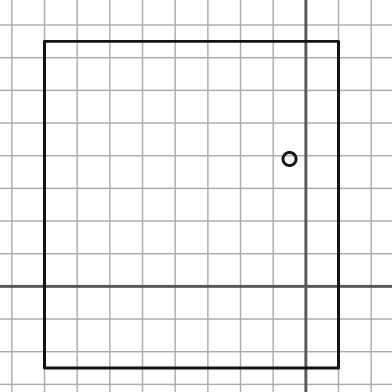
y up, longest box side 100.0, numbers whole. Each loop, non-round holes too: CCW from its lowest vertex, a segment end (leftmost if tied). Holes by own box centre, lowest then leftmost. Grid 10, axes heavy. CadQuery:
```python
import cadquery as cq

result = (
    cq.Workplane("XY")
    .moveTo(-80.0, -25.0)
    .lineTo(10.0, -25.0)
    .lineTo(10.0, 75.0)
    .lineTo(-80.0, 75.0)
    .close()
    .moveTo(-5.0, 39.0)
    .circle(2.0)
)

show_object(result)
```